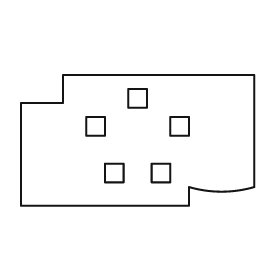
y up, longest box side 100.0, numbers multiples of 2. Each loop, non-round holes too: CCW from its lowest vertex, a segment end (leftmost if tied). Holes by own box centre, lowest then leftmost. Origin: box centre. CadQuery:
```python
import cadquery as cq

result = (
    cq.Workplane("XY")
    .moveTo(-50.0, -28.0)
    .lineTo(22.0, -28.0)
    .lineTo(22.0, -20.0)
    .threePointArc((36.0, -22.0), (50.0, -20.0))
    .lineTo(50.0, 28.0)
    .lineTo(-32.0, 28.0)
    .lineTo(-32.0, 16.0)
    .lineTo(-50.0, 16.0)
    .close()
    .moveTo(-14.0, -18.0)
    .lineTo(-6.0, -18.0)
    .lineTo(-6.0, -10.0)
    .lineTo(-14.0, -10.0)
    .close()
    .moveTo(6.0, -18.0)
    .lineTo(14.0, -18.0)
    .lineTo(14.0, -10.0)
    .lineTo(6.0, -10.0)
    .close()
    .moveTo(-22.0, 2.0)
    .lineTo(-14.0, 2.0)
    .lineTo(-14.0, 10.0)
    .lineTo(-22.0, 10.0)
    .close()
    .moveTo(14.0, 2.0)
    .lineTo(22.0, 2.0)
    .lineTo(22.0, 10.0)
    .lineTo(14.0, 10.0)
    .close()
    .moveTo(-4.0, 14.0)
    .lineTo(4.0, 14.0)
    .lineTo(4.0, 22.0)
    .lineTo(-4.0, 22.0)
    .close()
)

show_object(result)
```